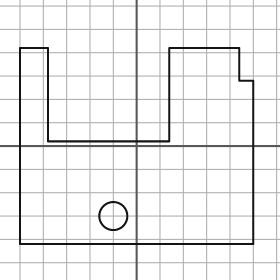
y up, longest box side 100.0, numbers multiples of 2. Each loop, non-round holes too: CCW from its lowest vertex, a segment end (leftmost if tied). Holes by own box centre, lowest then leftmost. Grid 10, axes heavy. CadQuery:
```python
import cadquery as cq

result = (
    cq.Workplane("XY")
    .moveTo(-50.0, -42.0)
    .lineTo(50.0, -42.0)
    .lineTo(50.0, 28.0)
    .lineTo(44.0, 28.0)
    .lineTo(44.0, 42.0)
    .lineTo(14.0, 42.0)
    .lineTo(14.0, 2.0)
    .lineTo(-38.0, 2.0)
    .lineTo(-38.0, 42.0)
    .lineTo(-50.0, 42.0)
    .close()
    .moveTo(-10.0, -30.0)
    .circle(6.0)
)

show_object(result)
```